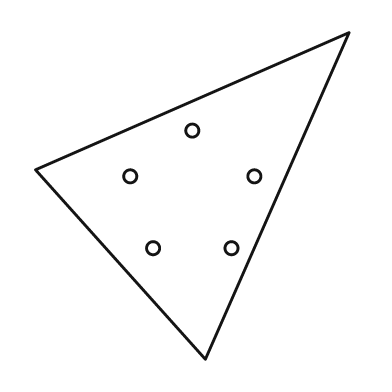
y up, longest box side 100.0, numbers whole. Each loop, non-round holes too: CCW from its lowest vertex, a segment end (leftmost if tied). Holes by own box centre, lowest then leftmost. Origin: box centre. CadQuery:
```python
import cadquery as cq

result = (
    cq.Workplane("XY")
    .moveTo(4.0, -50.0)
    .lineTo(48.0, 50.0)
    .lineTo(-48.0, 8.0)
    .close()
    .moveTo(-12.0, -16.0)
    .circle(2.0)
    .moveTo(12.0, -16.0)
    .circle(2.0)
    .moveTo(-19.0, 6.0)
    .circle(2.0)
    .moveTo(19.0, 6.0)
    .circle(2.0)
    .moveTo(0.0, 20.0)
    .circle(2.0)
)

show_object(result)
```